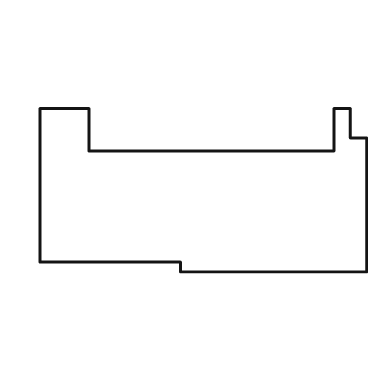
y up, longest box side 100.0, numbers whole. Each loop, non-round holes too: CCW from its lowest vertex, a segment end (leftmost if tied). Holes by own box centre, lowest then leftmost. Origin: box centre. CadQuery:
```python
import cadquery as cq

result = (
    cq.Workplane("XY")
    .moveTo(-7.0, -25.0)
    .lineTo(50.0, -25.0)
    .lineTo(50.0, 16.0)
    .lineTo(45.0, 16.0)
    .lineTo(45.0, 25.0)
    .lineTo(40.0, 25.0)
    .lineTo(40.0, 12.0)
    .lineTo(-35.0, 12.0)
    .lineTo(-35.0, 25.0)
    .lineTo(-50.0, 25.0)
    .lineTo(-50.0, -22.0)
    .lineTo(-7.0, -22.0)
    .close()
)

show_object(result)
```